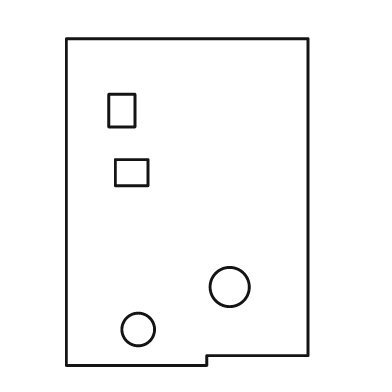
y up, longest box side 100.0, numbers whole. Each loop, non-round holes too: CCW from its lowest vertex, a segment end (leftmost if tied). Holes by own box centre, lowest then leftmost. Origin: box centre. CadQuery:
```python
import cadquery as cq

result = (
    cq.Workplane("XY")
    .moveTo(-37.0, -50.0)
    .lineTo(6.0, -50.0)
    .lineTo(6.0, -47.0)
    .lineTo(37.0, -47.0)
    .lineTo(37.0, 50.0)
    .lineTo(-37.0, 50.0)
    .close()
    .moveTo(-15.0, -39.0)
    .circle(5.0)
    .moveTo(13.0, -26.0)
    .circle(6.0)
    .moveTo(-22.0, 5.0)
    .lineTo(-12.0, 5.0)
    .lineTo(-12.0, 13.0)
    .lineTo(-22.0, 13.0)
    .close()
    .moveTo(-24.0, 23.0)
    .lineTo(-16.0, 23.0)
    .lineTo(-16.0, 33.0)
    .lineTo(-24.0, 33.0)
    .close()
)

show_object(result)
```